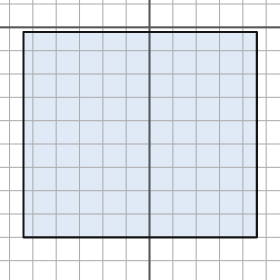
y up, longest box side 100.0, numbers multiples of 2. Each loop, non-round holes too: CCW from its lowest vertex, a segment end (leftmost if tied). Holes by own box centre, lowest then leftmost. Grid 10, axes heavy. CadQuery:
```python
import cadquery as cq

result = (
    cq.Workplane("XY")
    .moveTo(-54.0, -90.0)
    .lineTo(46.0, -90.0)
    .lineTo(46.0, -2.0)
    .lineTo(-54.0, -2.0)
    .close()
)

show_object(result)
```